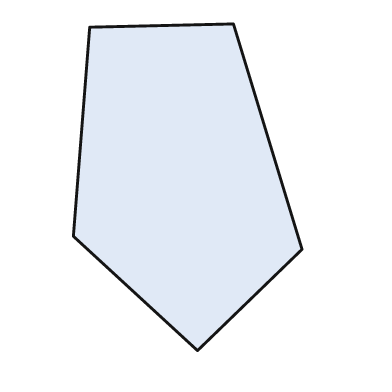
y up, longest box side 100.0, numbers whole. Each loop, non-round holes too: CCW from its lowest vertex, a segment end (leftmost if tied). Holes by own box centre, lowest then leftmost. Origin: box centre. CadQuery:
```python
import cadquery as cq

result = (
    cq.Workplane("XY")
    .moveTo(3.0, -50.0)
    .lineTo(35.0, -19.0)
    .lineTo(14.0, 50.0)
    .lineTo(-30.0, 49.0)
    .lineTo(-35.0, -15.0)
    .close()
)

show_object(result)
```